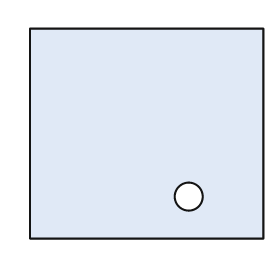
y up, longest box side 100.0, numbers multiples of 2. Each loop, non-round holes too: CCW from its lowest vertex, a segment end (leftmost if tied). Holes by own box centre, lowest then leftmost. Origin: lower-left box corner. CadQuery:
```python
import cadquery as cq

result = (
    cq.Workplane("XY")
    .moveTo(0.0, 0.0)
    .lineTo(100.0, 0.0)
    .lineTo(100.0, 90.0)
    .lineTo(0.0, 90.0)
    .close()
    .moveTo(68.0, 18.0)
    .circle(6.0)
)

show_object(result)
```